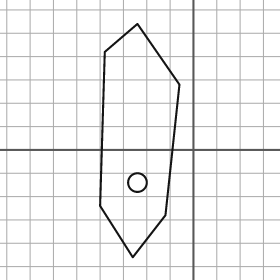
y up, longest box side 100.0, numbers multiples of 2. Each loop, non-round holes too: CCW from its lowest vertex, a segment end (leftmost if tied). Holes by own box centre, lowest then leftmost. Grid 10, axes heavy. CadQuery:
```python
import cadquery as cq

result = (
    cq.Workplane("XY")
    .moveTo(-26.0, -46.0)
    .lineTo(-12.0, -28.0)
    .lineTo(-6.0, 28.0)
    .lineTo(-24.0, 54.0)
    .lineTo(-38.0, 42.0)
    .lineTo(-40.0, -24.0)
    .close()
    .moveTo(-24.0, -14.0)
    .circle(4.0)
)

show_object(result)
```